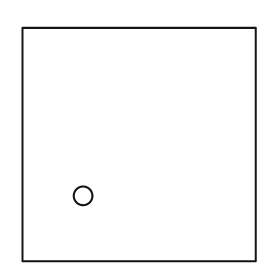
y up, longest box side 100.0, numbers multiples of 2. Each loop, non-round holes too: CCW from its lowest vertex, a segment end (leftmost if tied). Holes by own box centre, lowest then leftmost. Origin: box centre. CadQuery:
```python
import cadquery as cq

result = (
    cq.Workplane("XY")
    .moveTo(-50.0, -50.0)
    .lineTo(50.0, -50.0)
    .lineTo(50.0, 50.0)
    .lineTo(-50.0, 50.0)
    .close()
    .moveTo(-24.0, -22.0)
    .circle(4.0)
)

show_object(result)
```